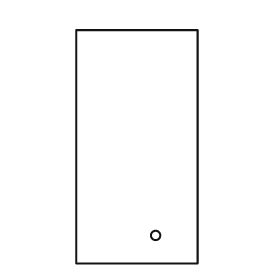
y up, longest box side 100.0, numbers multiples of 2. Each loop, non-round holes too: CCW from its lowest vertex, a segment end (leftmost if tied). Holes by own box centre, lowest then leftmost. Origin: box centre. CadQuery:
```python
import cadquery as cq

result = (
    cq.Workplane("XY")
    .moveTo(-26.0, -50.0)
    .lineTo(26.0, -50.0)
    .lineTo(26.0, 50.0)
    .lineTo(-26.0, 50.0)
    .close()
    .moveTo(8.0, -38.0)
    .circle(2.0)
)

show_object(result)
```